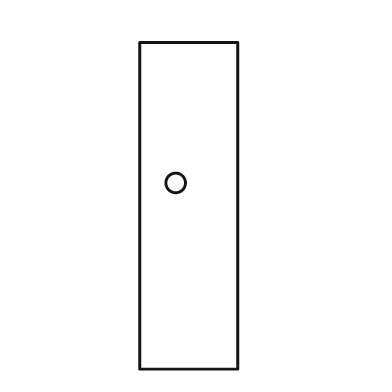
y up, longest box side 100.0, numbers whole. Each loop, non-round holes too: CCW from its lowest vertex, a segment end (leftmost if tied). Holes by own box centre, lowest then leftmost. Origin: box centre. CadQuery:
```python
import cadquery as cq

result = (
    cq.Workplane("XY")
    .moveTo(-15.0, -50.0)
    .lineTo(15.0, -50.0)
    .lineTo(15.0, 50.0)
    .lineTo(-15.0, 50.0)
    .close()
    .moveTo(-4.0, 7.0)
    .circle(3.0)
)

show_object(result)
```